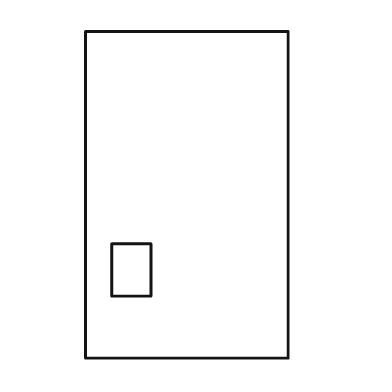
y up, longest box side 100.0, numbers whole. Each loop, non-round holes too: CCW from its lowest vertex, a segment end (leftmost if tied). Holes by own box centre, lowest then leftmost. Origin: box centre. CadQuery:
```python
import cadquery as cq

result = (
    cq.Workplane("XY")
    .moveTo(-31.0, -50.0)
    .lineTo(31.0, -50.0)
    .lineTo(31.0, 50.0)
    .lineTo(-31.0, 50.0)
    .close()
    .moveTo(-23.0, -31.0)
    .lineTo(-11.0, -31.0)
    .lineTo(-11.0, -15.0)
    .lineTo(-23.0, -15.0)
    .close()
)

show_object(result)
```